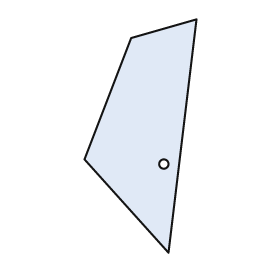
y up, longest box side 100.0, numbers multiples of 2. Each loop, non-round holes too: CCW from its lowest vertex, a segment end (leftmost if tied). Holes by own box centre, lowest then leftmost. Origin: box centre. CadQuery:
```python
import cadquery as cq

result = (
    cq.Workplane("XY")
    .moveTo(12.0, -50.0)
    .lineTo(24.0, 50.0)
    .lineTo(-4.0, 42.0)
    .lineTo(-24.0, -10.0)
    .close()
    .moveTo(10.0, -12.0)
    .circle(2.0)
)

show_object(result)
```